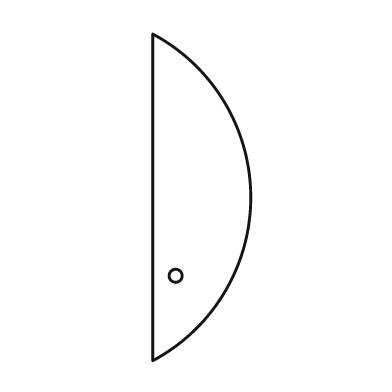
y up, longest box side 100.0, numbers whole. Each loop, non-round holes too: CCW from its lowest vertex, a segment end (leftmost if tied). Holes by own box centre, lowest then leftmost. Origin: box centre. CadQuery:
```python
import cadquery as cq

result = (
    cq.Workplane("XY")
    .moveTo(-15.0, -50.0)
    .threePointArc((15.0, 0.0), (-15.0, 50.0))
    .close()
    .moveTo(-8.0, -24.0)
    .circle(2.0)
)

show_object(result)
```